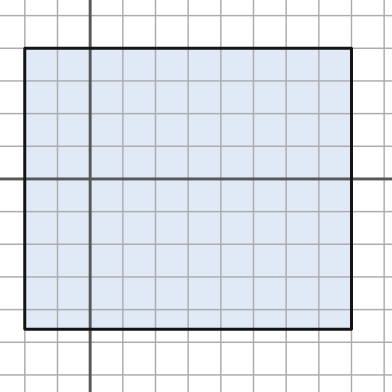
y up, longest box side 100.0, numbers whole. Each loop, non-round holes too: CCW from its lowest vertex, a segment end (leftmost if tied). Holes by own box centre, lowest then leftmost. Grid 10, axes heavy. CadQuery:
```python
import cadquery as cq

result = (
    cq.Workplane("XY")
    .moveTo(-20.0, -46.0)
    .lineTo(80.0, -46.0)
    .lineTo(80.0, 40.0)
    .lineTo(-20.0, 40.0)
    .close()
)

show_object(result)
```